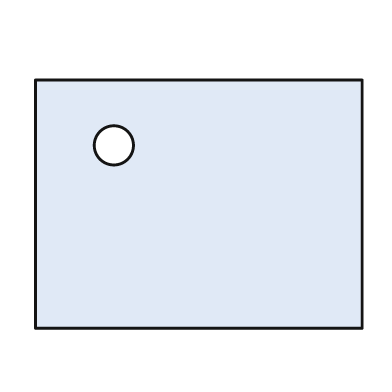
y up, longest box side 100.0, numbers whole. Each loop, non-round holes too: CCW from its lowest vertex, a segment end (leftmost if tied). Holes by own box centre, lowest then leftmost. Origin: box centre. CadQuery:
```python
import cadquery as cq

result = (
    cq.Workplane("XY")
    .moveTo(-50.0, -38.0)
    .lineTo(50.0, -38.0)
    .lineTo(50.0, 38.0)
    .lineTo(-50.0, 38.0)
    .close()
    .moveTo(-26.0, 18.0)
    .circle(6.0)
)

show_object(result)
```